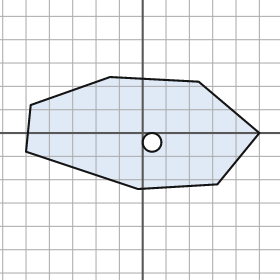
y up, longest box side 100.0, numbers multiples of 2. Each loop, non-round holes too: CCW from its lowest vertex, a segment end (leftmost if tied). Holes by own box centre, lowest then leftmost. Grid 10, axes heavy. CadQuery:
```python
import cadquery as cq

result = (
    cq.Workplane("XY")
    .moveTo(-2.0, -24.0)
    .lineTo(32.0, -22.0)
    .lineTo(50.0, 0.0)
    .lineTo(24.0, 22.0)
    .lineTo(-14.0, 24.0)
    .lineTo(-48.0, 12.0)
    .lineTo(-50.0, -8.0)
    .close()
    .moveTo(4.0, -4.0)
    .circle(4.0)
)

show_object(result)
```